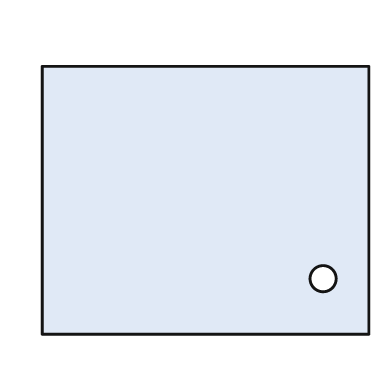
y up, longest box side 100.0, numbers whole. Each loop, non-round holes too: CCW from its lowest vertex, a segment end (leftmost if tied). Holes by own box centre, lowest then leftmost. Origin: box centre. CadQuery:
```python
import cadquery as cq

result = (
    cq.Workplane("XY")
    .moveTo(-50.0, -41.0)
    .lineTo(50.0, -41.0)
    .lineTo(50.0, 41.0)
    .lineTo(-50.0, 41.0)
    .close()
    .moveTo(36.0, -24.0)
    .circle(4.0)
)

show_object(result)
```